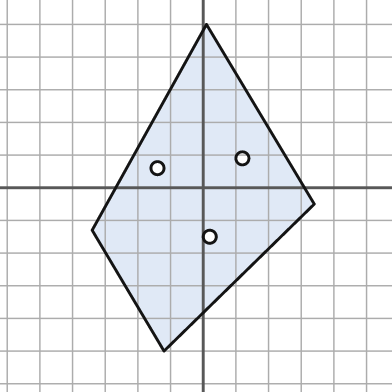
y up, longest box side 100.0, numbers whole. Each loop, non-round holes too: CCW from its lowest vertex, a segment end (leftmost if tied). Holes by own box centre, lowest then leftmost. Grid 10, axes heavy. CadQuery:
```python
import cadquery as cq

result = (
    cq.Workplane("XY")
    .moveTo(-12.0, -50.0)
    .lineTo(34.0, -5.0)
    .lineTo(1.0, 50.0)
    .lineTo(-34.0, -13.0)
    .close()
    .moveTo(2.0, -15.0)
    .circle(2.0)
    .moveTo(-14.0, 6.0)
    .circle(2.0)
    .moveTo(12.0, 9.0)
    .circle(2.0)
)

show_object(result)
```